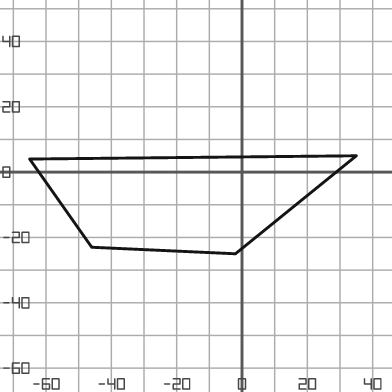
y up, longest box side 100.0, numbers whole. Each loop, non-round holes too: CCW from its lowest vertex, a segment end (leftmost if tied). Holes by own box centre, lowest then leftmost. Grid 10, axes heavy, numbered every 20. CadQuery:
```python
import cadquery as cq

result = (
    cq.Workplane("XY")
    .moveTo(-2.0, -25.0)
    .lineTo(35.0, 5.0)
    .lineTo(-65.0, 4.0)
    .lineTo(-46.0, -23.0)
    .close()
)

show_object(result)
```